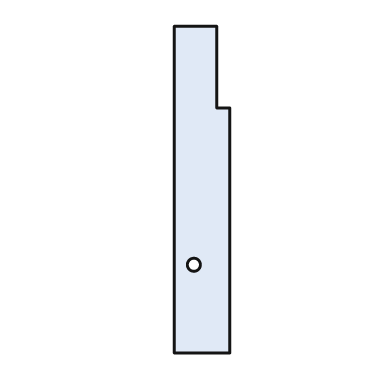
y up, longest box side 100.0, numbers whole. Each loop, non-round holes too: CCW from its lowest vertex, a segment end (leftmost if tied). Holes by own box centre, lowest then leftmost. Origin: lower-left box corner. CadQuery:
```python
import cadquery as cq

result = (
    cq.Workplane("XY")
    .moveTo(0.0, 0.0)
    .lineTo(17.0, 0.0)
    .lineTo(17.0, 75.0)
    .lineTo(13.0, 75.0)
    .lineTo(13.0, 100.0)
    .lineTo(0.0, 100.0)
    .close()
    .moveTo(6.0, 27.0)
    .circle(2.0)
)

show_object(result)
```